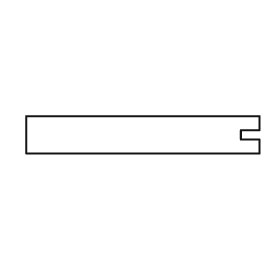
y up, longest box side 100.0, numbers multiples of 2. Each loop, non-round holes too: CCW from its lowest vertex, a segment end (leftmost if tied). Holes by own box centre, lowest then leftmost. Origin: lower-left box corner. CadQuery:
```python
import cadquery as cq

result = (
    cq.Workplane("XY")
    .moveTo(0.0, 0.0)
    .lineTo(100.0, 0.0)
    .lineTo(100.0, 6.0)
    .lineTo(92.0, 6.0)
    .lineTo(92.0, 10.0)
    .lineTo(100.0, 10.0)
    .lineTo(100.0, 16.0)
    .lineTo(0.0, 16.0)
    .close()
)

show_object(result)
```